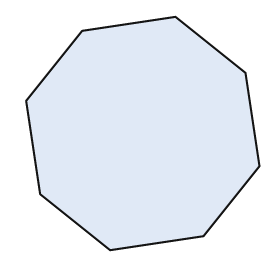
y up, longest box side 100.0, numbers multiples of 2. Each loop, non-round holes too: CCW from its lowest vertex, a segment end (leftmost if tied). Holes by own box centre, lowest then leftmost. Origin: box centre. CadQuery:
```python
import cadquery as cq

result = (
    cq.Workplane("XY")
    .moveTo(-14.0, -50.0)
    .lineTo(26.0, -44.0)
    .lineTo(50.0, -14.0)
    .lineTo(44.0, 26.0)
    .lineTo(14.0, 50.0)
    .lineTo(-26.0, 44.0)
    .lineTo(-50.0, 14.0)
    .lineTo(-44.0, -26.0)
    .close()
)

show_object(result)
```